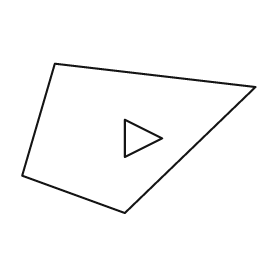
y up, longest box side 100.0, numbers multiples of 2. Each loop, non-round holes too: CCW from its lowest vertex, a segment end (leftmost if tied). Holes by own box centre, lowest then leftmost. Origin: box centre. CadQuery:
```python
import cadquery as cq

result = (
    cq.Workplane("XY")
    .moveTo(-6.0, -32.0)
    .lineTo(50.0, 22.0)
    .lineTo(-36.0, 32.0)
    .lineTo(-50.0, -16.0)
    .close()
    .moveTo(-6.0, -8.0)
    .lineTo(10.0, 0.0)
    .lineTo(-6.0, 8.0)
    .close()
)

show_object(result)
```